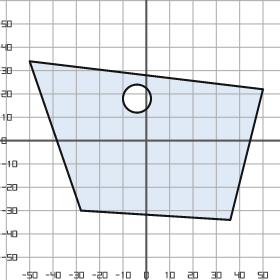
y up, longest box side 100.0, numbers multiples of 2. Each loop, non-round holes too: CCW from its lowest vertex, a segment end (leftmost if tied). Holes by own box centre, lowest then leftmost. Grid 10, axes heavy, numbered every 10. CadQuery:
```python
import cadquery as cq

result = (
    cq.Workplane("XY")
    .moveTo(36.0, -34.0)
    .lineTo(50.0, 22.0)
    .lineTo(-50.0, 34.0)
    .lineTo(-28.0, -30.0)
    .close()
    .moveTo(-4.0, 18.0)
    .circle(6.0)
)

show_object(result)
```